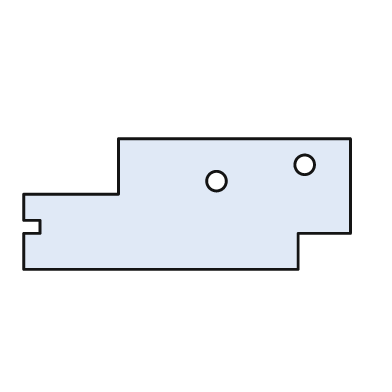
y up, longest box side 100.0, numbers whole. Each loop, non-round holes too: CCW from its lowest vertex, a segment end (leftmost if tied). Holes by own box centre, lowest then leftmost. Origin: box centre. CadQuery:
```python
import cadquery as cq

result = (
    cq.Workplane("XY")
    .moveTo(-50.0, -20.0)
    .lineTo(34.0, -20.0)
    .lineTo(34.0, -9.0)
    .lineTo(50.0, -9.0)
    .lineTo(50.0, 20.0)
    .lineTo(-21.0, 20.0)
    .lineTo(-21.0, 3.0)
    .lineTo(-50.0, 3.0)
    .lineTo(-50.0, -5.0)
    .lineTo(-45.0, -5.0)
    .lineTo(-45.0, -9.0)
    .lineTo(-50.0, -9.0)
    .close()
    .moveTo(9.0, 7.0)
    .circle(3.0)
    .moveTo(36.0, 12.0)
    .circle(3.0)
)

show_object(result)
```